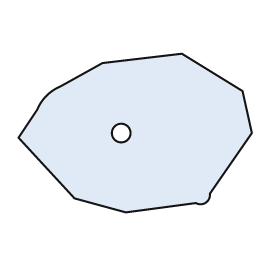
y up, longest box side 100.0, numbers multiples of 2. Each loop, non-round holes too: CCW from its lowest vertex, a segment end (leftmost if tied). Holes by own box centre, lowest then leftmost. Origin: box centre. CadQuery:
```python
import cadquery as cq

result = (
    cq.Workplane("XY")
    .moveTo(-4.0, -34.0)
    .lineTo(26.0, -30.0)
    .threePointArc((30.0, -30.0), (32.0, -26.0))
    .lineTo(50.0, 0.0)
    .lineTo(46.0, 18.0)
    .lineTo(20.0, 34.0)
    .lineTo(-14.0, 30.0)
    .lineTo(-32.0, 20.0)
    .threePointArc((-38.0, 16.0), (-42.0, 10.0))
    .lineTo(-50.0, -2.0)
    .lineTo(-26.0, -28.0)
    .close()
    .moveTo(-6.0, 0.0)
    .circle(4.0)
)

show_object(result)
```